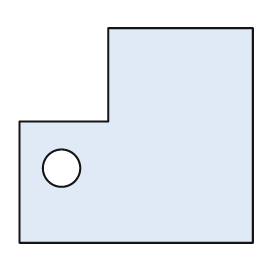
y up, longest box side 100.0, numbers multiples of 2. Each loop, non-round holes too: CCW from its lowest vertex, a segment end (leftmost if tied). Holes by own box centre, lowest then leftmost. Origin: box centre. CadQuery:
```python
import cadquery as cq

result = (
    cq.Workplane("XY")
    .moveTo(-50.0, -46.0)
    .lineTo(50.0, -46.0)
    .lineTo(50.0, 46.0)
    .lineTo(-12.0, 46.0)
    .lineTo(-12.0, 6.0)
    .lineTo(-50.0, 6.0)
    .close()
    .moveTo(-32.0, -14.0)
    .circle(8.0)
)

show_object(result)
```